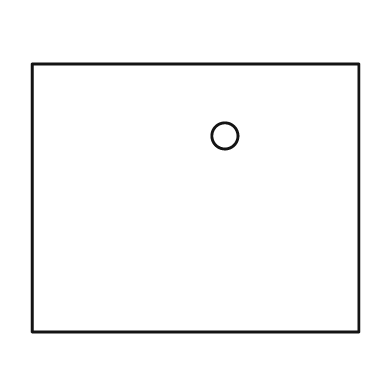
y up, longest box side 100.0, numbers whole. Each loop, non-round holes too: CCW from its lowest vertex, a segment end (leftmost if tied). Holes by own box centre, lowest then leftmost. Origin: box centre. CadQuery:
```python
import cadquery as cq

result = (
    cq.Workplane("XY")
    .moveTo(-50.0, -41.0)
    .lineTo(50.0, -41.0)
    .lineTo(50.0, 41.0)
    .lineTo(-50.0, 41.0)
    .close()
    .moveTo(9.0, 19.0)
    .circle(4.0)
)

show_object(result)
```